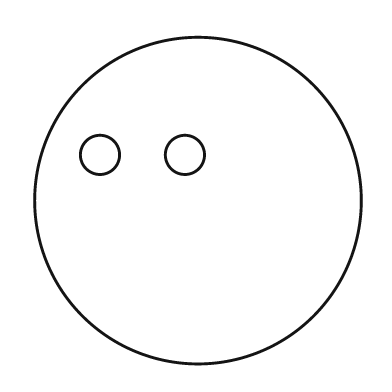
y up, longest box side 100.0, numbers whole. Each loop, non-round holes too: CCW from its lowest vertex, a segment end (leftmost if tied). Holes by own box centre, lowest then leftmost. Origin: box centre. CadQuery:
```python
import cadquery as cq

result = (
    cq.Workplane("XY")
    .moveTo(0.0, 0.0)
    .circle(50.0)
    .moveTo(-30.0, 14.0)
    .circle(6.0)
    .moveTo(-4.0, 14.0)
    .circle(6.0)
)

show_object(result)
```